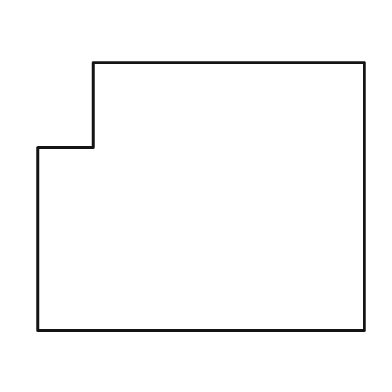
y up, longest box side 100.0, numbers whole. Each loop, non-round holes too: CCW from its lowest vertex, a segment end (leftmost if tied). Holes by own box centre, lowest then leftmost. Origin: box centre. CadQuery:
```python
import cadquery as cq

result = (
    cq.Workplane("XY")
    .moveTo(-50.0, -41.0)
    .lineTo(50.0, -41.0)
    .lineTo(50.0, 41.0)
    .lineTo(-33.0, 41.0)
    .lineTo(-33.0, 15.0)
    .lineTo(-50.0, 15.0)
    .close()
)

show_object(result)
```